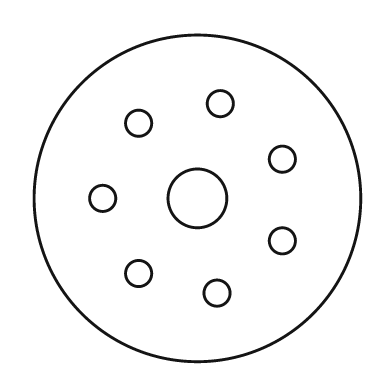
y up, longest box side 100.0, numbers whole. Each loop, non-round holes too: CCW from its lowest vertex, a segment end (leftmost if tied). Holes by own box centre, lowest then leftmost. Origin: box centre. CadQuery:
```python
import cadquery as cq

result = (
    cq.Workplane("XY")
    .moveTo(0.0, 0.0)
    .circle(50.0)
    .moveTo(6.0, -29.0)
    .circle(4.0)
    .moveTo(-18.0, -23.0)
    .circle(4.0)
    .moveTo(26.0, -13.0)
    .circle(4.0)
    .moveTo(-29.0, 0.0)
    .circle(4.0)
    .moveTo(0.0, 0.0)
    .circle(9.0)
    .moveTo(26.0, 12.0)
    .circle(4.0)
    .moveTo(-18.0, 23.0)
    .circle(4.0)
    .moveTo(7.0, 29.0)
    .circle(4.0)
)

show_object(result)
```